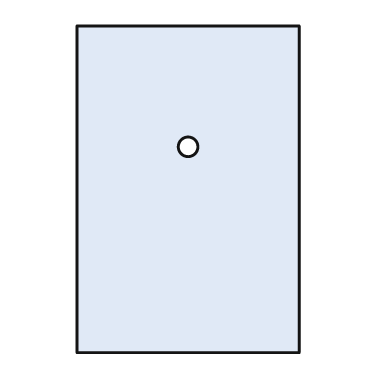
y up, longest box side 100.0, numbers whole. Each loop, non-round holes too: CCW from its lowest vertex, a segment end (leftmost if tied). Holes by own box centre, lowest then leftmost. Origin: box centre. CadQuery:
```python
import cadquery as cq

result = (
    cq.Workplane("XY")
    .moveTo(-34.0, -50.0)
    .lineTo(34.0, -50.0)
    .lineTo(34.0, 50.0)
    .lineTo(-34.0, 50.0)
    .close()
    .moveTo(0.0, 13.0)
    .circle(3.0)
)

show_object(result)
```